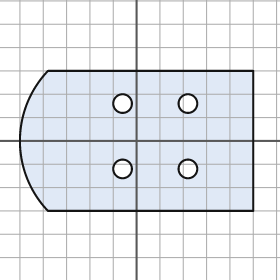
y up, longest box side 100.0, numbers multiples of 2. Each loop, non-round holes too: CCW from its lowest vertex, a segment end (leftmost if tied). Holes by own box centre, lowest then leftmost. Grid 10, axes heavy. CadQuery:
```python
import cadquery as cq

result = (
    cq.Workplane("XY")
    .moveTo(-38.0, -30.0)
    .lineTo(50.0, -30.0)
    .lineTo(50.0, 30.0)
    .lineTo(-38.0, 30.0)
    .threePointArc((-50.0, 0.0), (-38.0, -30.0))
    .close()
    .moveTo(-6.0, -12.0)
    .circle(4.0)
    .moveTo(22.0, -12.0)
    .circle(4.0)
    .moveTo(-6.0, 16.0)
    .circle(4.0)
    .moveTo(22.0, 16.0)
    .circle(4.0)
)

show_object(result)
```